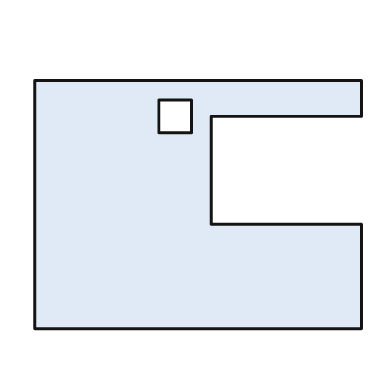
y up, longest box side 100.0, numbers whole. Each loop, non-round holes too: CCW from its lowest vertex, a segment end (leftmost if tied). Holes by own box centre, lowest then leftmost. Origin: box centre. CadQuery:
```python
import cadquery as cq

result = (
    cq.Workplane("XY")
    .moveTo(-50.0, -38.0)
    .lineTo(50.0, -38.0)
    .lineTo(50.0, -6.0)
    .lineTo(4.0, -6.0)
    .lineTo(4.0, 27.0)
    .lineTo(50.0, 27.0)
    .lineTo(50.0, 38.0)
    .lineTo(-50.0, 38.0)
    .close()
    .moveTo(-12.0, 22.0)
    .lineTo(-2.0, 22.0)
    .lineTo(-2.0, 32.0)
    .lineTo(-12.0, 32.0)
    .close()
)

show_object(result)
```